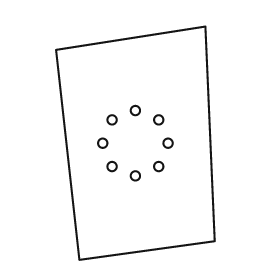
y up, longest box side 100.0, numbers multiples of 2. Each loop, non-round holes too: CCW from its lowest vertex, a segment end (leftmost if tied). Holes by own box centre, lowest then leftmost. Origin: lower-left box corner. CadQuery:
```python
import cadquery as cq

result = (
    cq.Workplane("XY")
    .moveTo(10.0, 0.0)
    .lineTo(68.0, 8.0)
    .lineTo(64.0, 100.0)
    .lineTo(0.0, 90.0)
    .close()
    .moveTo(34.0, 36.0)
    .circle(2.0)
    .moveTo(24.0, 40.0)
    .circle(2.0)
    .moveTo(44.0, 40.0)
    .circle(2.0)
    .moveTo(20.0, 50.0)
    .circle(2.0)
    .moveTo(48.0, 50.0)
    .circle(2.0)
    .moveTo(24.0, 60.0)
    .circle(2.0)
    .moveTo(44.0, 60.0)
    .circle(2.0)
    .moveTo(34.0, 64.0)
    .circle(2.0)
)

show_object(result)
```